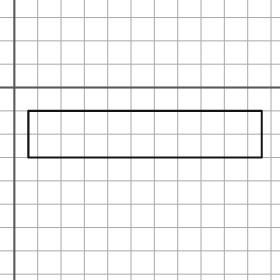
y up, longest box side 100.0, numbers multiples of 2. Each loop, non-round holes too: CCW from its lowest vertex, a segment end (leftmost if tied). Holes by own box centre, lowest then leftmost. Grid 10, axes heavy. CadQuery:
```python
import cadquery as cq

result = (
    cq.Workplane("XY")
    .moveTo(6.0, -30.0)
    .lineTo(106.0, -30.0)
    .lineTo(106.0, -10.0)
    .lineTo(6.0, -10.0)
    .close()
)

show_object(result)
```